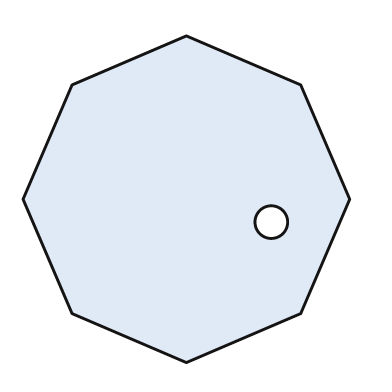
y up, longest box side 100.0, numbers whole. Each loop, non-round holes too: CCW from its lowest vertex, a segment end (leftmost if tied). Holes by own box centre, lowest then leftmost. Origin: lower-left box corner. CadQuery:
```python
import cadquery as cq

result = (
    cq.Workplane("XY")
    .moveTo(50.0, 0.0)
    .lineTo(85.0, 15.0)
    .lineTo(100.0, 50.0)
    .lineTo(85.0, 85.0)
    .lineTo(50.0, 100.0)
    .lineTo(15.0, 85.0)
    .lineTo(0.0, 50.0)
    .lineTo(15.0, 15.0)
    .close()
    .moveTo(76.0, 43.0)
    .circle(5.0)
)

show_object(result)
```